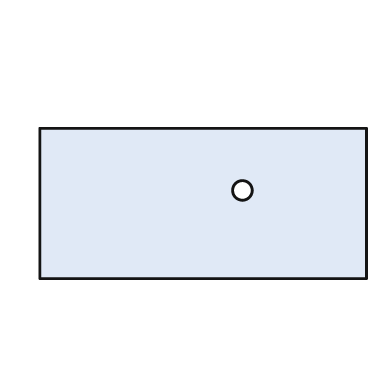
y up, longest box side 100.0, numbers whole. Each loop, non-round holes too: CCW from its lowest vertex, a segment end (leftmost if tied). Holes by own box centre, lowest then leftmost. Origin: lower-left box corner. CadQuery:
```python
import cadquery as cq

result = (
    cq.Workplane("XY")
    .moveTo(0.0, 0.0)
    .lineTo(100.0, 0.0)
    .lineTo(100.0, 46.0)
    .lineTo(0.0, 46.0)
    .close()
    .moveTo(62.0, 27.0)
    .circle(3.0)
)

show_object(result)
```